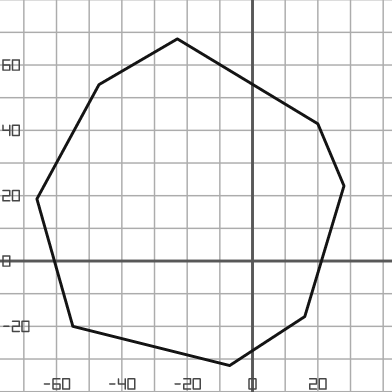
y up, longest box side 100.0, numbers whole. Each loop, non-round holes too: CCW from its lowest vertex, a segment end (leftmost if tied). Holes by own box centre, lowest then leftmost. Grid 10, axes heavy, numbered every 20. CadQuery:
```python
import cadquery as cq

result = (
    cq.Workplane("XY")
    .moveTo(-7.0, -32.0)
    .lineTo(16.0, -17.0)
    .lineTo(28.0, 23.0)
    .lineTo(20.0, 42.0)
    .lineTo(-23.0, 68.0)
    .lineTo(-47.0, 54.0)
    .lineTo(-66.0, 19.0)
    .lineTo(-55.0, -20.0)
    .close()
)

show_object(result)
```